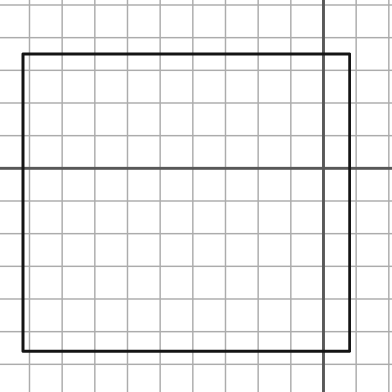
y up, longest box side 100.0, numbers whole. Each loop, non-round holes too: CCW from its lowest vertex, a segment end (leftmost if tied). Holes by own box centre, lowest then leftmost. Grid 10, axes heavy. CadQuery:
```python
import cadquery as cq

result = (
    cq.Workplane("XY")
    .moveTo(-92.0, -56.0)
    .lineTo(8.0, -56.0)
    .lineTo(8.0, 35.0)
    .lineTo(-92.0, 35.0)
    .close()
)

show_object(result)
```